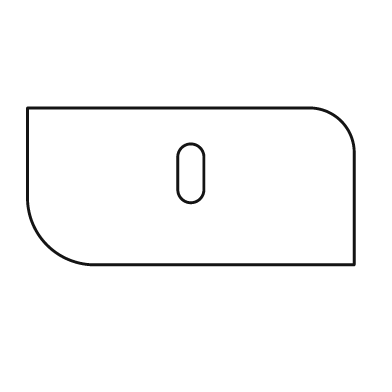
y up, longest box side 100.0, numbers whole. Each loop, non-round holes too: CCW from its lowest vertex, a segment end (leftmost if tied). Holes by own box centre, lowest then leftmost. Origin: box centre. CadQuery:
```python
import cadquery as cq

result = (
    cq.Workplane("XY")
    .moveTo(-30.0, -24.0)
    .lineTo(50.0, -24.0)
    .lineTo(50.0, 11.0)
    .threePointArc((46.0, 20.0), (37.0, 24.0))
    .lineTo(-50.0, 24.0)
    .lineTo(-50.0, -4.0)
    .threePointArc((-44.0, -18.0), (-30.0, -24.0))
    .close()
    .moveTo(-4.0, -1.0)
    .threePointArc((0.0, -5.0), (4.0, -1.0))
    .lineTo(4.0, 9.0)
    .threePointArc((0.0, 13.0), (-4.0, 9.0))
    .close()
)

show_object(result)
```